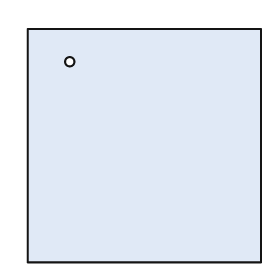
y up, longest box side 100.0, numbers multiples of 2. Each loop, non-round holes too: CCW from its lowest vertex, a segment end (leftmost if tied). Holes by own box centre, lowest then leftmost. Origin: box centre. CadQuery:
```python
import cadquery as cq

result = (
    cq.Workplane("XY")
    .moveTo(-50.0, -50.0)
    .lineTo(50.0, -50.0)
    .lineTo(50.0, 50.0)
    .lineTo(-50.0, 50.0)
    .close()
    .moveTo(-32.0, 36.0)
    .circle(2.0)
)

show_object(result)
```